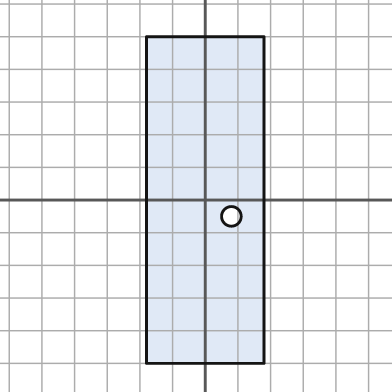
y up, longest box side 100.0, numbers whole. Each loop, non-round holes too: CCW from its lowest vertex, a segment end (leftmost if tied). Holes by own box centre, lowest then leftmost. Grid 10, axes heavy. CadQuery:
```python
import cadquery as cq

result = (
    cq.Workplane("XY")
    .moveTo(-18.0, -50.0)
    .lineTo(18.0, -50.0)
    .lineTo(18.0, 50.0)
    .lineTo(-18.0, 50.0)
    .close()
    .moveTo(8.0, -5.0)
    .circle(3.0)
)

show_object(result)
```